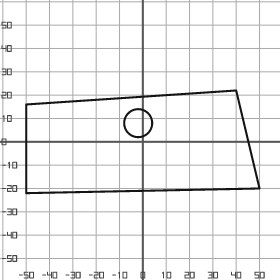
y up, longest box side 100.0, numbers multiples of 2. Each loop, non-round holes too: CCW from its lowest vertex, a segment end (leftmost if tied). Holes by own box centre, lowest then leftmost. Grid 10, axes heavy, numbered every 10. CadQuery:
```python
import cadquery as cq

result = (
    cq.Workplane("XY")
    .moveTo(-50.0, -22.0)
    .lineTo(50.0, -20.0)
    .lineTo(40.0, 22.0)
    .lineTo(-50.0, 16.0)
    .close()
    .moveTo(-2.0, 8.0)
    .circle(6.0)
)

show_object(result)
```